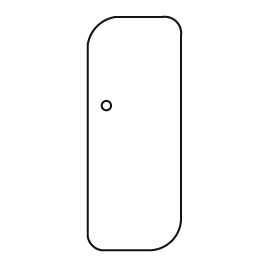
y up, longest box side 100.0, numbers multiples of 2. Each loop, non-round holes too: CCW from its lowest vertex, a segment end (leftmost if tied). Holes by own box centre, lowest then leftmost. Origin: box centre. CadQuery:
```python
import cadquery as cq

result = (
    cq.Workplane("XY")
    .moveTo(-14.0, -50.0)
    .lineTo(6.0, -50.0)
    .threePointArc((16.0, -46.0), (20.0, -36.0))
    .lineTo(20.0, 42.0)
    .threePointArc((18.0, 48.0), (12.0, 50.0))
    .lineTo(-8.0, 50.0)
    .threePointArc((-16.0, 46.0), (-20.0, 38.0))
    .lineTo(-20.0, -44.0)
    .threePointArc((-18.0, -48.0), (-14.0, -50.0))
    .close()
    .moveTo(-12.0, 12.0)
    .circle(2.0)
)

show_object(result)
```